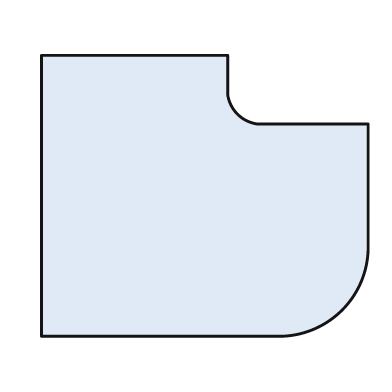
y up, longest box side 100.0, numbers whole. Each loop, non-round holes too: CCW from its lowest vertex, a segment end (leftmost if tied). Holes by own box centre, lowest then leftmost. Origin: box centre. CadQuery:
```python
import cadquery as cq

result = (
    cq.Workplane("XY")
    .moveTo(-50.0, -43.0)
    .lineTo(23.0, -43.0)
    .threePointArc((42.0, -35.0), (50.0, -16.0))
    .lineTo(50.0, 22.0)
    .lineTo(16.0, 22.0)
    .threePointArc((10.0, 25.0), (7.0, 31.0))
    .lineTo(7.0, 43.0)
    .lineTo(-50.0, 43.0)
    .close()
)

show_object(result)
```